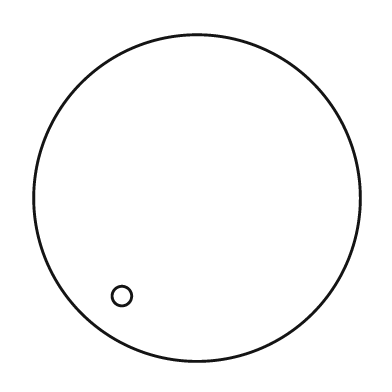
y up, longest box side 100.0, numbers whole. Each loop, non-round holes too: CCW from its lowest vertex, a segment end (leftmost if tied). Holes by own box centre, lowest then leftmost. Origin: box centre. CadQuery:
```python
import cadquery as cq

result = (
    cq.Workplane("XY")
    .moveTo(0.0, 0.0)
    .circle(50.0)
    .moveTo(-23.0, -30.0)
    .circle(3.0)
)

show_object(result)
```